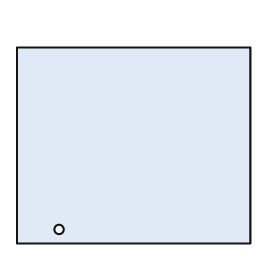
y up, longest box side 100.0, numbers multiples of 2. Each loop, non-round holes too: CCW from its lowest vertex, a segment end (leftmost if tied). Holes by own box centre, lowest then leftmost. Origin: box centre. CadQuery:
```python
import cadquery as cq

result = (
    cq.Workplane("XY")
    .moveTo(-50.0, -42.0)
    .lineTo(50.0, -42.0)
    .lineTo(50.0, 42.0)
    .lineTo(-50.0, 42.0)
    .close()
    .moveTo(-32.0, -36.0)
    .circle(2.0)
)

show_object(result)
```